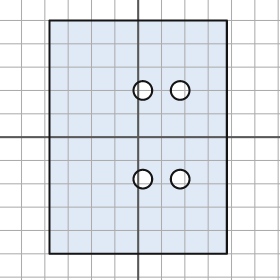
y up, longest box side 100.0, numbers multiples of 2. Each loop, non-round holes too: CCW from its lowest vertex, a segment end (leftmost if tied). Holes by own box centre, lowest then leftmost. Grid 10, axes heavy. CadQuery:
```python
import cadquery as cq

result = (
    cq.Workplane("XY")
    .moveTo(-38.0, -50.0)
    .lineTo(38.0, -50.0)
    .lineTo(38.0, 50.0)
    .lineTo(-38.0, 50.0)
    .close()
    .moveTo(2.0, -18.0)
    .circle(4.0)
    .moveTo(18.0, -18.0)
    .circle(4.0)
    .moveTo(2.0, 20.0)
    .circle(4.0)
    .moveTo(18.0, 20.0)
    .circle(4.0)
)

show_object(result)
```